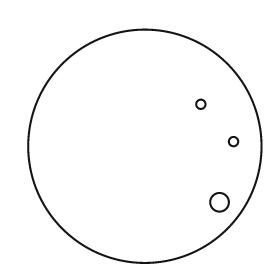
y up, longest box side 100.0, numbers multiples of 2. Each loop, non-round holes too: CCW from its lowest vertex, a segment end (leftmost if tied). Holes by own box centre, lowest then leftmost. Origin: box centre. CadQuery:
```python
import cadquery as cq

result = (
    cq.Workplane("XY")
    .moveTo(0.0, 0.0)
    .circle(50.0)
    .moveTo(32.0, -24.0)
    .circle(4.0)
    .moveTo(38.0, 2.0)
    .circle(2.0)
    .moveTo(24.0, 18.0)
    .circle(2.0)
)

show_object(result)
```